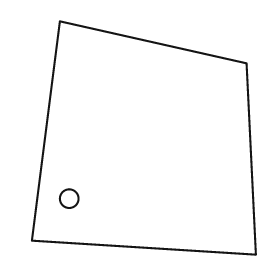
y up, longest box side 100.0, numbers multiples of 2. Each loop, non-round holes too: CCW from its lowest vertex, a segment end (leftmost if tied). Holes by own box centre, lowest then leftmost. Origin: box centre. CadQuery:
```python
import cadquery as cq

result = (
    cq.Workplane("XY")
    .moveTo(48.0, -50.0)
    .lineTo(44.0, 32.0)
    .lineTo(-36.0, 50.0)
    .lineTo(-48.0, -44.0)
    .close()
    .moveTo(-32.0, -26.0)
    .circle(4.0)
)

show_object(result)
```